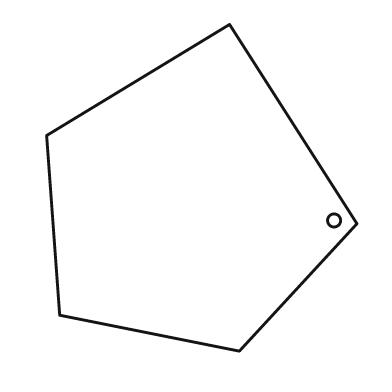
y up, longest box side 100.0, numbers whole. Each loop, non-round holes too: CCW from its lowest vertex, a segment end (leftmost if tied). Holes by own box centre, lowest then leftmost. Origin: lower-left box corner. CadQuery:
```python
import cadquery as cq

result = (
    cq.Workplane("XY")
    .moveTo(59.0, 0.0)
    .lineTo(95.0, 39.0)
    .lineTo(56.0, 100.0)
    .lineTo(0.0, 66.0)
    .lineTo(4.0, 11.0)
    .close()
    .moveTo(88.0, 40.0)
    .circle(2.0)
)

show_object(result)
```